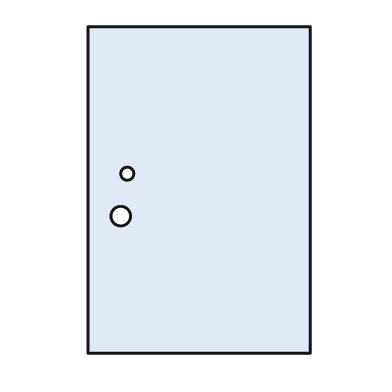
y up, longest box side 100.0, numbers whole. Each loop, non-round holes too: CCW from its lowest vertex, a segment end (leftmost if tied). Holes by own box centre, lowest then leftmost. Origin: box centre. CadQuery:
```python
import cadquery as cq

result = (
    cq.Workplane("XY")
    .moveTo(-34.0, -50.0)
    .lineTo(34.0, -50.0)
    .lineTo(34.0, 50.0)
    .lineTo(-34.0, 50.0)
    .close()
    .moveTo(-24.0, -8.0)
    .circle(3.0)
    .moveTo(-22.0, 5.0)
    .circle(2.0)
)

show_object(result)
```